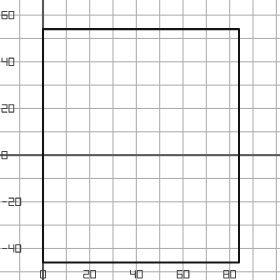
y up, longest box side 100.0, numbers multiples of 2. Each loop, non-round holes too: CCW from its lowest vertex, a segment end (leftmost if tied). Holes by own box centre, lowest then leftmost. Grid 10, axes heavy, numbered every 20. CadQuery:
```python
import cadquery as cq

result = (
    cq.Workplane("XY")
    .moveTo(0.0, -46.0)
    .lineTo(84.0, -46.0)
    .lineTo(84.0, 54.0)
    .lineTo(0.0, 54.0)
    .close()
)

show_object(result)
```